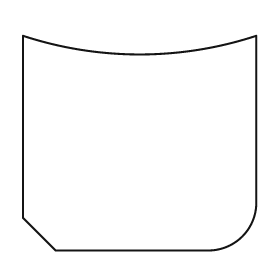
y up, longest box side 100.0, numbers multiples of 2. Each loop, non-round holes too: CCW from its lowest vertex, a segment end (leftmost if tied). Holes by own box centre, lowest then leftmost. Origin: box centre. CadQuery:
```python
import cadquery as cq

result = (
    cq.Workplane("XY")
    .moveTo(-36.0, -46.0)
    .lineTo(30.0, -46.0)
    .threePointArc((44.0, -40.0), (50.0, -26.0))
    .lineTo(50.0, 46.0)
    .threePointArc((0.0, 38.0), (-50.0, 46.0))
    .lineTo(-50.0, -32.0)
    .close()
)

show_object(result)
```